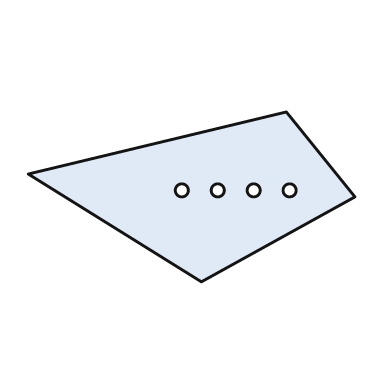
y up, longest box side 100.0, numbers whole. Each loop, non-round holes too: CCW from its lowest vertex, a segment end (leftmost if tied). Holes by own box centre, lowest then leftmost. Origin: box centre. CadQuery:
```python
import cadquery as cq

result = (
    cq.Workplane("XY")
    .moveTo(3.0, -26.0)
    .lineTo(50.0, 0.0)
    .lineTo(29.0, 26.0)
    .lineTo(-50.0, 7.0)
    .close()
    .moveTo(-3.0, 2.0)
    .circle(2.0)
    .moveTo(8.0, 2.0)
    .circle(2.0)
    .moveTo(19.0, 2.0)
    .circle(2.0)
    .moveTo(30.0, 2.0)
    .circle(2.0)
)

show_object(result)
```